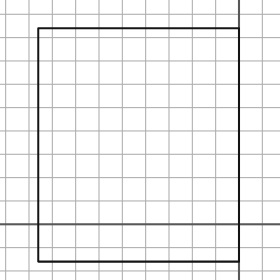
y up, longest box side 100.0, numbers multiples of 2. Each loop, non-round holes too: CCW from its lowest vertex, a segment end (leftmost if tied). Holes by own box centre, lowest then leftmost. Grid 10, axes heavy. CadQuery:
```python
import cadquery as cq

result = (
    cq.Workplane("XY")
    .moveTo(-86.0, -16.0)
    .lineTo(0.0, -16.0)
    .lineTo(0.0, 84.0)
    .lineTo(-86.0, 84.0)
    .close()
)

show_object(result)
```